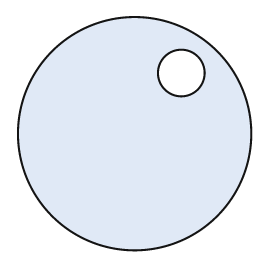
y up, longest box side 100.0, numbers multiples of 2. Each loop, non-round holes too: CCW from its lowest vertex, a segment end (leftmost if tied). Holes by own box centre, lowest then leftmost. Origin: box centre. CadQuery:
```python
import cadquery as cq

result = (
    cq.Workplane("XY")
    .moveTo(0.0, 0.0)
    .circle(50.0)
    .moveTo(20.0, 26.0)
    .circle(10.0)
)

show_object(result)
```